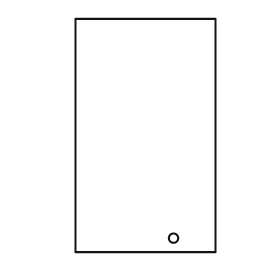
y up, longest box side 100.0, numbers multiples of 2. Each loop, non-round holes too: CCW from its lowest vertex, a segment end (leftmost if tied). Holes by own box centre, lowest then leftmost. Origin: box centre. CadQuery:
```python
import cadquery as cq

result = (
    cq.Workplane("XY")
    .moveTo(-30.0, -50.0)
    .lineTo(30.0, -50.0)
    .lineTo(30.0, 50.0)
    .lineTo(-30.0, 50.0)
    .close()
    .moveTo(12.0, -44.0)
    .circle(2.0)
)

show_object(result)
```